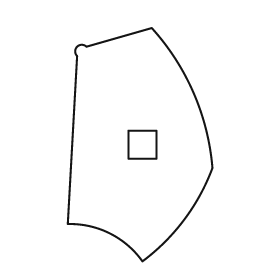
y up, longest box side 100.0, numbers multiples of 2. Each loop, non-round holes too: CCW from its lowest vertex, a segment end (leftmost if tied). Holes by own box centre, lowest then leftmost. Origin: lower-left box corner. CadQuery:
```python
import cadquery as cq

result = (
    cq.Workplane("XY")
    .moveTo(32.0, 0.0)
    .threePointArc((50.0, 18.0), (62.0, 40.0))
    .threePointArc((54.0, 72.0), (36.0, 100.0))
    .lineTo(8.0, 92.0)
    .threePointArc((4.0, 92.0), (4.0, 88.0))
    .lineTo(0.0, 16.0)
    .threePointArc((18.0, 12.0), (32.0, 0.0))
    .close()
    .moveTo(26.0, 44.0)
    .lineTo(38.0, 44.0)
    .lineTo(38.0, 56.0)
    .lineTo(26.0, 56.0)
    .close()
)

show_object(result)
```